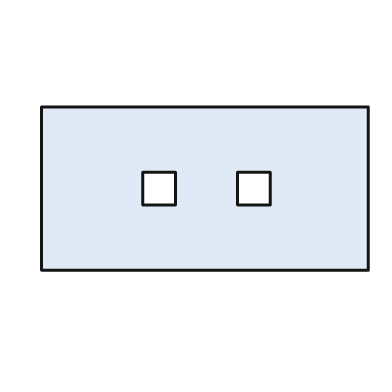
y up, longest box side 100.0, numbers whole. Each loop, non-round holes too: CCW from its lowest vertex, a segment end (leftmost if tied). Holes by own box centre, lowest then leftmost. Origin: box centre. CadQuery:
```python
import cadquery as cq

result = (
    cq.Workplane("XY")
    .moveTo(-50.0, -25.0)
    .lineTo(50.0, -25.0)
    .lineTo(50.0, 25.0)
    .lineTo(-50.0, 25.0)
    .close()
    .moveTo(-19.0, -5.0)
    .lineTo(-9.0, -5.0)
    .lineTo(-9.0, 5.0)
    .lineTo(-19.0, 5.0)
    .close()
    .moveTo(10.0, -5.0)
    .lineTo(20.0, -5.0)
    .lineTo(20.0, 5.0)
    .lineTo(10.0, 5.0)
    .close()
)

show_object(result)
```